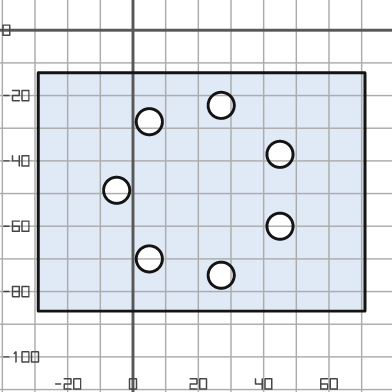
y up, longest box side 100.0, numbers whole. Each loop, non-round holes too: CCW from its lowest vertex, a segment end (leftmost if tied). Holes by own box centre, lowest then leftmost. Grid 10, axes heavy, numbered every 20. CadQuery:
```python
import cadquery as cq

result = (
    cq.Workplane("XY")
    .moveTo(-29.0, -86.0)
    .lineTo(71.0, -86.0)
    .lineTo(71.0, -13.0)
    .lineTo(-29.0, -13.0)
    .close()
    .moveTo(27.0, -75.0)
    .circle(4.0)
    .moveTo(5.0, -70.0)
    .circle(4.0)
    .moveTo(45.0, -60.0)
    .circle(4.0)
    .moveTo(-5.0, -49.0)
    .circle(4.0)
    .moveTo(45.0, -38.0)
    .circle(4.0)
    .moveTo(5.0, -28.0)
    .circle(4.0)
    .moveTo(27.0, -23.0)
    .circle(4.0)
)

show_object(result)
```